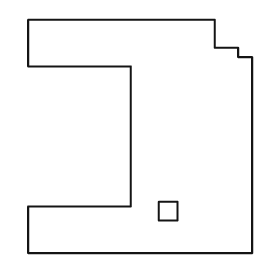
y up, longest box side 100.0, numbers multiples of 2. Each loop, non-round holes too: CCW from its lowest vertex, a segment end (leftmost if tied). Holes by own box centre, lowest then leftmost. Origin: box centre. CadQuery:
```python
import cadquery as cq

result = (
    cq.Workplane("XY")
    .moveTo(-48.0, -50.0)
    .lineTo(48.0, -50.0)
    .lineTo(48.0, 34.0)
    .lineTo(42.0, 34.0)
    .lineTo(42.0, 38.0)
    .lineTo(32.0, 38.0)
    .lineTo(32.0, 50.0)
    .lineTo(-48.0, 50.0)
    .lineTo(-48.0, 30.0)
    .lineTo(-4.0, 30.0)
    .lineTo(-4.0, -30.0)
    .lineTo(-48.0, -30.0)
    .close()
    .moveTo(8.0, -36.0)
    .lineTo(16.0, -36.0)
    .lineTo(16.0, -28.0)
    .lineTo(8.0, -28.0)
    .close()
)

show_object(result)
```